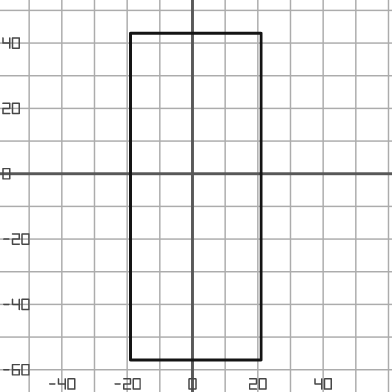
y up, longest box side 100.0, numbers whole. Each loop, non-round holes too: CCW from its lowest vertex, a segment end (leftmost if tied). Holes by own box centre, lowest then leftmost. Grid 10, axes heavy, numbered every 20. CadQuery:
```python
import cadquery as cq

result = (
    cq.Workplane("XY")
    .moveTo(-19.0, -57.0)
    .lineTo(21.0, -57.0)
    .lineTo(21.0, 43.0)
    .lineTo(-19.0, 43.0)
    .close()
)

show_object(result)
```